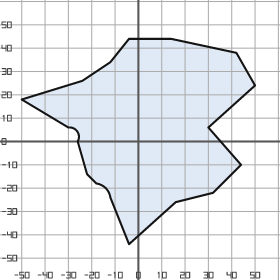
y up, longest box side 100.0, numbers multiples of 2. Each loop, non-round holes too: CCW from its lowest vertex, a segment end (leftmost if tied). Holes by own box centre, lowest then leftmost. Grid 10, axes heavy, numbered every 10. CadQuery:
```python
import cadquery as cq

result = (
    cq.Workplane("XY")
    .moveTo(-4.0, -44.0)
    .lineTo(16.0, -26.0)
    .lineTo(32.0, -22.0)
    .lineTo(44.0, -10.0)
    .lineTo(30.0, 6.0)
    .lineTo(50.0, 24.0)
    .lineTo(42.0, 38.0)
    .lineTo(14.0, 44.0)
    .lineTo(-4.0, 44.0)
    .lineTo(-12.0, 34.0)
    .lineTo(-24.0, 26.0)
    .lineTo(-50.0, 18.0)
    .lineTo(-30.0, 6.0)
    .threePointArc((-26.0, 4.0), (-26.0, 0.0))
    .lineTo(-22.0, -14.0)
    .lineTo(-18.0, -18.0)
    .threePointArc((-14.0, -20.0), (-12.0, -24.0))
    .close()
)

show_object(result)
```